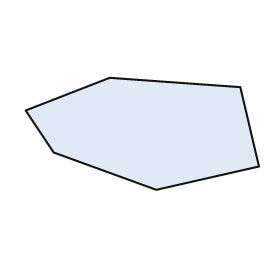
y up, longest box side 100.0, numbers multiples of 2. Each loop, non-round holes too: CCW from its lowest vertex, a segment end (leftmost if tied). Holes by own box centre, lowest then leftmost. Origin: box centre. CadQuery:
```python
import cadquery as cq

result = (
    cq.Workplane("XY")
    .moveTo(6.0, -24.0)
    .lineTo(50.0, -14.0)
    .lineTo(42.0, 20.0)
    .lineTo(-14.0, 24.0)
    .lineTo(-50.0, 10.0)
    .lineTo(-38.0, -8.0)
    .close()
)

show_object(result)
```